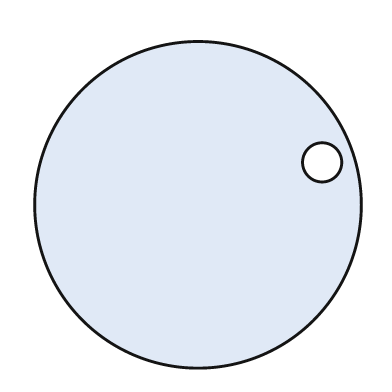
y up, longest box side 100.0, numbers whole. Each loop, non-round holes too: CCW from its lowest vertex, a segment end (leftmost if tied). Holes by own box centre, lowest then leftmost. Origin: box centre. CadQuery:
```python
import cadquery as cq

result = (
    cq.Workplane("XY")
    .moveTo(0.0, 0.0)
    .circle(50.0)
    .moveTo(38.0, 13.0)
    .circle(6.0)
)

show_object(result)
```